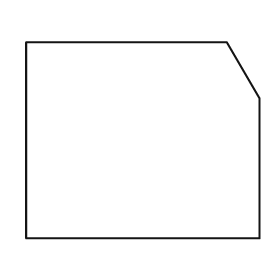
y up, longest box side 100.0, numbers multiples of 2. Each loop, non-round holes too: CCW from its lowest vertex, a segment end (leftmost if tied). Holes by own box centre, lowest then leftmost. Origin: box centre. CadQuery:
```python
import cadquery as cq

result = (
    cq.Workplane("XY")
    .moveTo(-50.0, -42.0)
    .lineTo(50.0, -42.0)
    .lineTo(50.0, 18.0)
    .lineTo(36.0, 42.0)
    .lineTo(-50.0, 42.0)
    .close()
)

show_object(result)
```